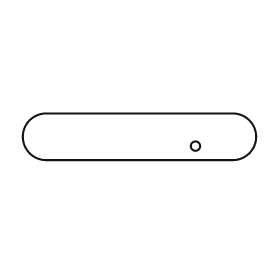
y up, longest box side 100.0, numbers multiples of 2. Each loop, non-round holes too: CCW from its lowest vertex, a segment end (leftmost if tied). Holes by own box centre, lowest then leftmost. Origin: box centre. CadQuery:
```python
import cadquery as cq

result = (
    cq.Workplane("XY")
    .moveTo(-40.0, -10.0)
    .lineTo(40.0, -10.0)
    .threePointArc((50.0, 0.0), (40.0, 10.0))
    .lineTo(-40.0, 10.0)
    .threePointArc((-50.0, 0.0), (-40.0, -10.0))
    .close()
    .moveTo(24.0, -4.0)
    .circle(2.0)
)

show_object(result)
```